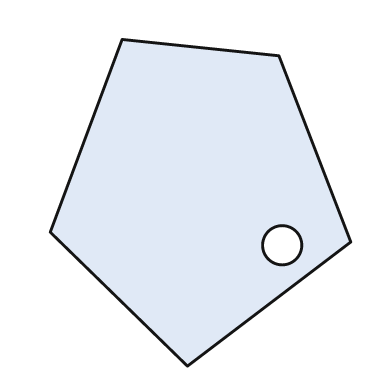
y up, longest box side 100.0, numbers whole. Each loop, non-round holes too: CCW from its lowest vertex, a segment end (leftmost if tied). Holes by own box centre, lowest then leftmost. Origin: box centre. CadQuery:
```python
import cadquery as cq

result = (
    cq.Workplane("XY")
    .moveTo(-4.0, -50.0)
    .lineTo(46.0, -12.0)
    .lineTo(24.0, 45.0)
    .lineTo(-24.0, 50.0)
    .lineTo(-46.0, -9.0)
    .close()
    .moveTo(25.0, -13.0)
    .circle(6.0)
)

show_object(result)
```